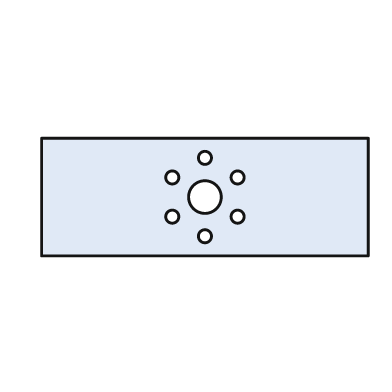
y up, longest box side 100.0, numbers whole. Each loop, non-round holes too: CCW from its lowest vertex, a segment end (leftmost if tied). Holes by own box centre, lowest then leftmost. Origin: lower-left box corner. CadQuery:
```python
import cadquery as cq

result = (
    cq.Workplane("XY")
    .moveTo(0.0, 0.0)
    .lineTo(100.0, 0.0)
    .lineTo(100.0, 36.0)
    .lineTo(0.0, 36.0)
    .close()
    .moveTo(50.0, 6.0)
    .circle(2.0)
    .moveTo(40.0, 12.0)
    .circle(2.0)
    .moveTo(60.0, 12.0)
    .circle(2.0)
    .moveTo(50.0, 18.0)
    .circle(5.0)
    .moveTo(40.0, 24.0)
    .circle(2.0)
    .moveTo(60.0, 24.0)
    .circle(2.0)
    .moveTo(50.0, 30.0)
    .circle(2.0)
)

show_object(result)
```